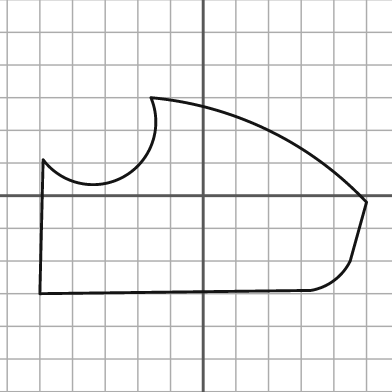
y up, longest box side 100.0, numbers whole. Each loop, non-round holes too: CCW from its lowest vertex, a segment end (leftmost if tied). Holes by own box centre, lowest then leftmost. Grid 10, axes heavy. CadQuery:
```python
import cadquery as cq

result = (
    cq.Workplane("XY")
    .moveTo(-50.0, -30.0)
    .lineTo(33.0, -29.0)
    .threePointArc((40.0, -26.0), (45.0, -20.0))
    .lineTo(50.0, -2.0)
    .threePointArc((20.0, 20.0), (-16.0, 30.0))
    .threePointArc((-24.0, 6.0), (-49.0, 11.0))
    .close()
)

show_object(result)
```